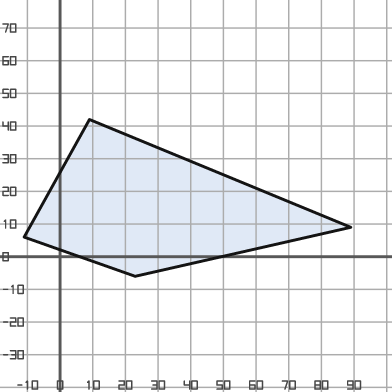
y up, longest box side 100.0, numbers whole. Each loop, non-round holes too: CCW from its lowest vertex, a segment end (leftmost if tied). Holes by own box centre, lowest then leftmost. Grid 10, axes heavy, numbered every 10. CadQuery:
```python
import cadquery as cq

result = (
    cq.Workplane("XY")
    .moveTo(23.0, -6.0)
    .lineTo(89.0, 9.0)
    .lineTo(9.0, 42.0)
    .lineTo(-11.0, 6.0)
    .close()
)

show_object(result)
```